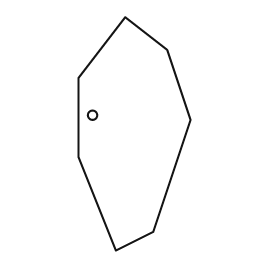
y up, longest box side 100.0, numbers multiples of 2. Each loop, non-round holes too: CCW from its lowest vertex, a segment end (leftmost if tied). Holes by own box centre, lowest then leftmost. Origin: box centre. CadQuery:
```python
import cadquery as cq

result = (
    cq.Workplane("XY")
    .moveTo(-8.0, -50.0)
    .lineTo(8.0, -42.0)
    .lineTo(24.0, 6.0)
    .lineTo(14.0, 36.0)
    .lineTo(-4.0, 50.0)
    .lineTo(-24.0, 24.0)
    .lineTo(-24.0, -10.0)
    .close()
    .moveTo(-18.0, 8.0)
    .circle(2.0)
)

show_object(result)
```